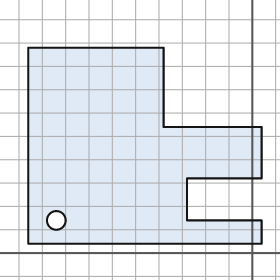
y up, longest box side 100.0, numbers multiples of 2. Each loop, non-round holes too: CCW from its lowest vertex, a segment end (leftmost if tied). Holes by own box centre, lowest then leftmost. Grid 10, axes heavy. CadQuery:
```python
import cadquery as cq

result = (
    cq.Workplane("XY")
    .moveTo(-96.0, 4.0)
    .lineTo(4.0, 4.0)
    .lineTo(4.0, 14.0)
    .lineTo(-28.0, 14.0)
    .lineTo(-28.0, 32.0)
    .lineTo(4.0, 32.0)
    .lineTo(4.0, 54.0)
    .lineTo(-38.0, 54.0)
    .lineTo(-38.0, 88.0)
    .lineTo(-96.0, 88.0)
    .close()
    .moveTo(-84.0, 14.0)
    .circle(4.0)
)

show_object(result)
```